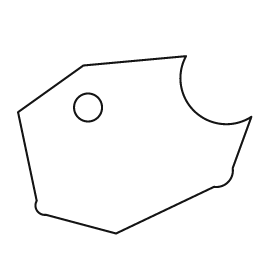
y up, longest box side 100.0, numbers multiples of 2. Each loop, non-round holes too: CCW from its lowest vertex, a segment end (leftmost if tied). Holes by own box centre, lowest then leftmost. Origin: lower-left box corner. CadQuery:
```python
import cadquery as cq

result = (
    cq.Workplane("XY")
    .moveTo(42.0, 0.0)
    .lineTo(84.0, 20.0)
    .threePointArc((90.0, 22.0), (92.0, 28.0))
    .lineTo(100.0, 50.0)
    .threePointArc((76.0, 52.0), (72.0, 76.0))
    .lineTo(28.0, 72.0)
    .lineTo(0.0, 52.0)
    .lineTo(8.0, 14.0)
    .threePointArc((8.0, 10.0), (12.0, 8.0))
    .close()
    .moveTo(30.0, 54.0)
    .circle(6.0)
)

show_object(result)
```